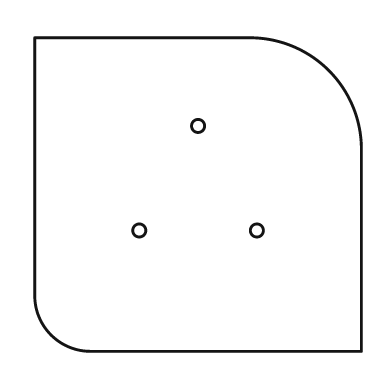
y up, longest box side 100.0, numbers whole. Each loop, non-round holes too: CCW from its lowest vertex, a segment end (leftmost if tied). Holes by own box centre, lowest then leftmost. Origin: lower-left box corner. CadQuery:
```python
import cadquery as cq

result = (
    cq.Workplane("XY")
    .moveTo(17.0, 0.0)
    .lineTo(100.0, 0.0)
    .lineTo(100.0, 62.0)
    .threePointArc((90.0, 86.0), (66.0, 96.0))
    .lineTo(0.0, 96.0)
    .lineTo(0.0, 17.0)
    .threePointArc((5.0, 5.0), (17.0, 0.0))
    .close()
    .moveTo(32.0, 37.0)
    .circle(2.0)
    .moveTo(68.0, 37.0)
    .circle(2.0)
    .moveTo(50.0, 69.0)
    .circle(2.0)
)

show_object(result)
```